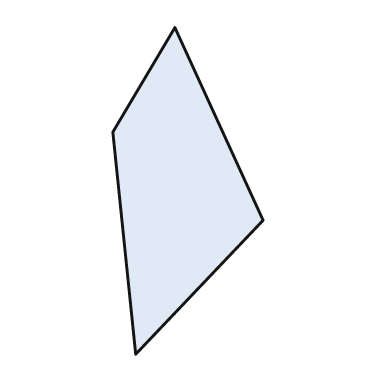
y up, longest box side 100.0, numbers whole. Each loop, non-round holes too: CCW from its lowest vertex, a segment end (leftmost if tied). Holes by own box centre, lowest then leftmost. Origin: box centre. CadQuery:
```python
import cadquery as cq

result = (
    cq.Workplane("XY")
    .moveTo(-16.0, -50.0)
    .lineTo(23.0, -9.0)
    .lineTo(-4.0, 50.0)
    .lineTo(-23.0, 18.0)
    .close()
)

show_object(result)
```